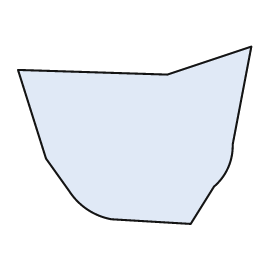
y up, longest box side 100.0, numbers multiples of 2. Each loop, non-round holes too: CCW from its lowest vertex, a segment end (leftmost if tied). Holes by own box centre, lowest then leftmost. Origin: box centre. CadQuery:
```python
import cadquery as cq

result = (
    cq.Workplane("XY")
    .moveTo(24.0, -38.0)
    .lineTo(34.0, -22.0)
    .threePointArc((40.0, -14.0), (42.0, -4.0))
    .lineTo(50.0, 38.0)
    .lineTo(14.0, 26.0)
    .lineTo(-50.0, 28.0)
    .lineTo(-38.0, -10.0)
    .lineTo(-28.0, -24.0)
    .threePointArc((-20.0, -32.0), (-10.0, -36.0))
    .close()
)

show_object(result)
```